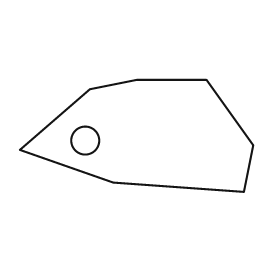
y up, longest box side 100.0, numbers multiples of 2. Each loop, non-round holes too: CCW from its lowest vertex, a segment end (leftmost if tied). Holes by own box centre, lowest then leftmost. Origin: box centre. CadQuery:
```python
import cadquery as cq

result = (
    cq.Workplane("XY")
    .moveTo(46.0, -24.0)
    .lineTo(50.0, -4.0)
    .lineTo(30.0, 24.0)
    .lineTo(0.0, 24.0)
    .lineTo(-20.0, 20.0)
    .lineTo(-50.0, -6.0)
    .lineTo(-10.0, -20.0)
    .close()
    .moveTo(-22.0, -2.0)
    .circle(6.0)
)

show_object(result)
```